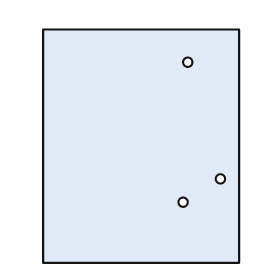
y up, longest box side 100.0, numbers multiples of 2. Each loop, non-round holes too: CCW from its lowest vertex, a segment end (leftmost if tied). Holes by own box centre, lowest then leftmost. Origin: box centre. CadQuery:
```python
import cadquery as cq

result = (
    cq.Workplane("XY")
    .moveTo(-42.0, -50.0)
    .lineTo(42.0, -50.0)
    .lineTo(42.0, 50.0)
    .lineTo(-42.0, 50.0)
    .close()
    .moveTo(18.0, -24.0)
    .circle(2.0)
    .moveTo(34.0, -14.0)
    .circle(2.0)
    .moveTo(20.0, 36.0)
    .circle(2.0)
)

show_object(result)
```